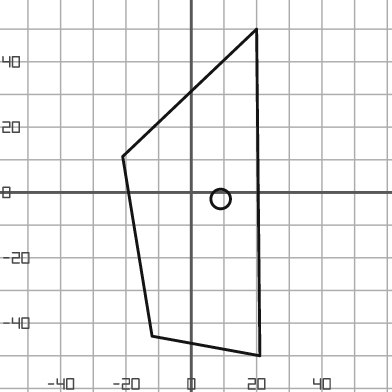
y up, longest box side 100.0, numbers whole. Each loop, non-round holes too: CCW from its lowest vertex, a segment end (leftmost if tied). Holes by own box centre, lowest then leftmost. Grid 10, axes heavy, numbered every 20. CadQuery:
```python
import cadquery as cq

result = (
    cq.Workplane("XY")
    .moveTo(21.0, -50.0)
    .lineTo(20.0, 50.0)
    .lineTo(-21.0, 11.0)
    .lineTo(-12.0, -44.0)
    .close()
    .moveTo(9.0, -2.0)
    .circle(3.0)
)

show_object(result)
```